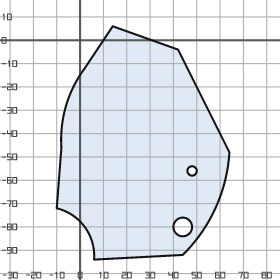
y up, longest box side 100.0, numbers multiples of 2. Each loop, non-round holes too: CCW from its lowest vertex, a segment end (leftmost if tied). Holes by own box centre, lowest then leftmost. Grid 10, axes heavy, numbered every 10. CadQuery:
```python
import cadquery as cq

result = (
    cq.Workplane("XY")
    .moveTo(6.0, -94.0)
    .lineTo(44.0, -92.0)
    .threePointArc((58.0, -72.0), (64.0, -48.0))
    .lineTo(42.0, -4.0)
    .lineTo(14.0, 6.0)
    .lineTo(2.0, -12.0)
    .threePointArc((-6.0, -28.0), (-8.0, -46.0))
    .lineTo(-10.0, -72.0)
    .threePointArc((2.0, -80.0), (6.0, -94.0))
    .close()
    .moveTo(44.0, -80.0)
    .circle(4.0)
    .moveTo(48.0, -56.0)
    .circle(2.0)
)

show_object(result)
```